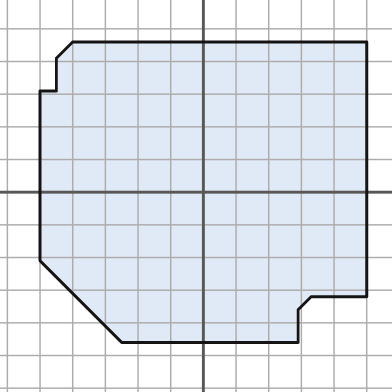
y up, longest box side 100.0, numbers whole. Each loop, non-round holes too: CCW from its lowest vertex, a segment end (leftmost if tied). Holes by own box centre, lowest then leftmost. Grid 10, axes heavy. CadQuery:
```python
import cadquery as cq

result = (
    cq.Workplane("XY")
    .moveTo(-25.0, -46.0)
    .lineTo(29.0, -46.0)
    .lineTo(29.0, -36.0)
    .lineTo(33.0, -32.0)
    .lineTo(50.0, -32.0)
    .lineTo(50.0, 46.0)
    .lineTo(-40.0, 46.0)
    .lineTo(-45.0, 41.0)
    .lineTo(-45.0, 31.0)
    .lineTo(-50.0, 31.0)
    .lineTo(-50.0, -21.0)
    .close()
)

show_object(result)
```